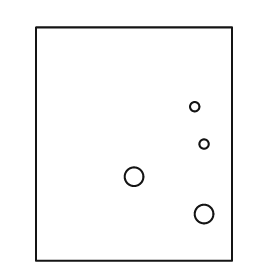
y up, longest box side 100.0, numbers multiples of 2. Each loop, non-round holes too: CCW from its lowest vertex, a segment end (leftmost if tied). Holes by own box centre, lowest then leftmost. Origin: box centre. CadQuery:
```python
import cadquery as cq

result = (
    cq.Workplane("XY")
    .moveTo(-42.0, -50.0)
    .lineTo(42.0, -50.0)
    .lineTo(42.0, 50.0)
    .lineTo(-42.0, 50.0)
    .close()
    .moveTo(30.0, -30.0)
    .circle(4.0)
    .moveTo(0.0, -14.0)
    .circle(4.0)
    .moveTo(30.0, 0.0)
    .circle(2.0)
    .moveTo(26.0, 16.0)
    .circle(2.0)
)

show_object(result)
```